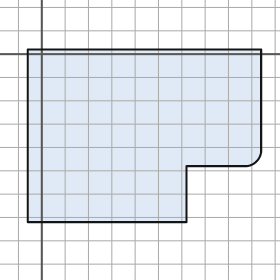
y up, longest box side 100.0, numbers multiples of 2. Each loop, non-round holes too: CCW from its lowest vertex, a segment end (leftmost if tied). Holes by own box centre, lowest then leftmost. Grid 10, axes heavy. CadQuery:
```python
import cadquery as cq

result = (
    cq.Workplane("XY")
    .moveTo(-6.0, -72.0)
    .lineTo(62.0, -72.0)
    .lineTo(62.0, -48.0)
    .lineTo(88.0, -48.0)
    .threePointArc((92.0, -46.0), (94.0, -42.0))
    .lineTo(94.0, 2.0)
    .lineTo(-6.0, 2.0)
    .close()
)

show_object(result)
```